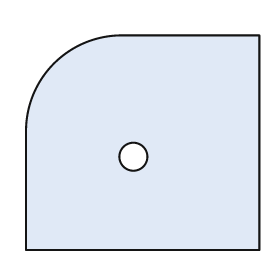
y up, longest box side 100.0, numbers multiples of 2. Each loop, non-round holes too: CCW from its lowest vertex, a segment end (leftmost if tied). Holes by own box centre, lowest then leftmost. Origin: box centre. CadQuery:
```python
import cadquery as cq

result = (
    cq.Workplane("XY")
    .moveTo(-50.0, -46.0)
    .lineTo(50.0, -46.0)
    .lineTo(50.0, 46.0)
    .lineTo(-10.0, 46.0)
    .threePointArc((-38.0, 34.0), (-50.0, 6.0))
    .close()
    .moveTo(-4.0, -6.0)
    .circle(6.0)
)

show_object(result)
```